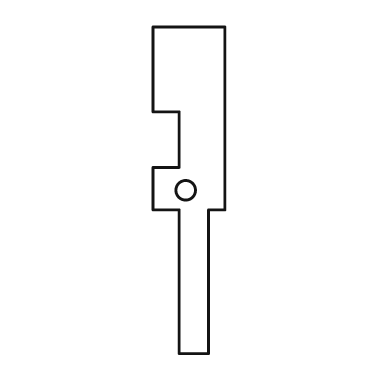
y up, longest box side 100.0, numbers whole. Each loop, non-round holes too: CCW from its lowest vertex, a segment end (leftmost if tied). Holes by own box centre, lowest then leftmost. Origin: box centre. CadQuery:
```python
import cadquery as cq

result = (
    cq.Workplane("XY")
    .moveTo(-3.0, -50.0)
    .lineTo(6.0, -50.0)
    .lineTo(6.0, -6.0)
    .lineTo(11.0, -6.0)
    .lineTo(11.0, 50.0)
    .lineTo(-11.0, 50.0)
    .lineTo(-11.0, 24.0)
    .lineTo(-3.0, 24.0)
    .lineTo(-3.0, 7.0)
    .lineTo(-11.0, 7.0)
    .lineTo(-11.0, -6.0)
    .lineTo(-3.0, -6.0)
    .close()
    .moveTo(-1.0, 0.0)
    .circle(3.0)
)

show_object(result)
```